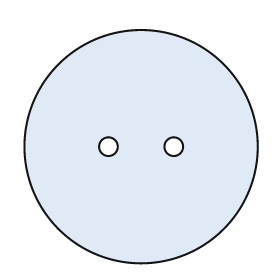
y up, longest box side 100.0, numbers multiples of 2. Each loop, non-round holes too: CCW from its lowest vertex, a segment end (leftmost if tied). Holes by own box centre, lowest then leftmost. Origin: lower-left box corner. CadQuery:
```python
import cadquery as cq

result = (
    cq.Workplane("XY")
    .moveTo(50.0, 50.0)
    .circle(50.0)
    .moveTo(36.0, 50.0)
    .circle(4.0)
    .moveTo(64.0, 50.0)
    .circle(4.0)
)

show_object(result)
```